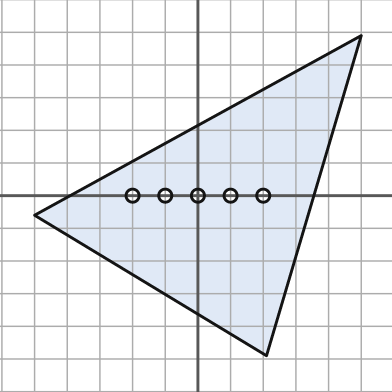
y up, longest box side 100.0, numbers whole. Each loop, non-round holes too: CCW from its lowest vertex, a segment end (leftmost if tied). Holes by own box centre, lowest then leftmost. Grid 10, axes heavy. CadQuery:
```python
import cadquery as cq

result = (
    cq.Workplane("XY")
    .moveTo(21.0, -49.0)
    .lineTo(50.0, 49.0)
    .lineTo(-50.0, -6.0)
    .close()
    .moveTo(-20.0, 0.0)
    .circle(2.0)
    .moveTo(-10.0, 0.0)
    .circle(2.0)
    .moveTo(0.0, 0.0)
    .circle(2.0)
    .moveTo(10.0, 0.0)
    .circle(2.0)
    .moveTo(20.0, 0.0)
    .circle(2.0)
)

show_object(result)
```